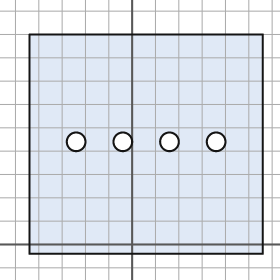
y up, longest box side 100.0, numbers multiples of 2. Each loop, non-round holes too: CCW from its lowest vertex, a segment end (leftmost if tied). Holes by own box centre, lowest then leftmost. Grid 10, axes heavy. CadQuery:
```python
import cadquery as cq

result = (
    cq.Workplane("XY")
    .moveTo(-44.0, -4.0)
    .lineTo(56.0, -4.0)
    .lineTo(56.0, 90.0)
    .lineTo(-44.0, 90.0)
    .close()
    .moveTo(-24.0, 44.0)
    .circle(4.0)
    .moveTo(-4.0, 44.0)
    .circle(4.0)
    .moveTo(16.0, 44.0)
    .circle(4.0)
    .moveTo(36.0, 44.0)
    .circle(4.0)
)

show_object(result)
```